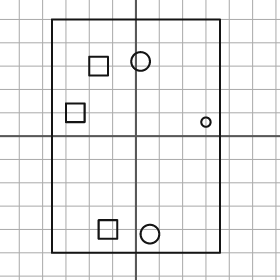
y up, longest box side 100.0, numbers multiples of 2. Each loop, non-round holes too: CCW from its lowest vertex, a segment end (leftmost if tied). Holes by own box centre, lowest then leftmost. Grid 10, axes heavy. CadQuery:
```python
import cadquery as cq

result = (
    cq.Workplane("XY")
    .moveTo(-36.0, -50.0)
    .lineTo(36.0, -50.0)
    .lineTo(36.0, 50.0)
    .lineTo(-36.0, 50.0)
    .close()
    .moveTo(6.0, -42.0)
    .circle(4.0)
    .moveTo(-16.0, -44.0)
    .lineTo(-8.0, -44.0)
    .lineTo(-8.0, -36.0)
    .lineTo(-16.0, -36.0)
    .close()
    .moveTo(30.0, 6.0)
    .circle(2.0)
    .moveTo(-30.0, 6.0)
    .lineTo(-22.0, 6.0)
    .lineTo(-22.0, 14.0)
    .lineTo(-30.0, 14.0)
    .close()
    .moveTo(-20.0, 26.0)
    .lineTo(-12.0, 26.0)
    .lineTo(-12.0, 34.0)
    .lineTo(-20.0, 34.0)
    .close()
    .moveTo(2.0, 32.0)
    .circle(4.0)
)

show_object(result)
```